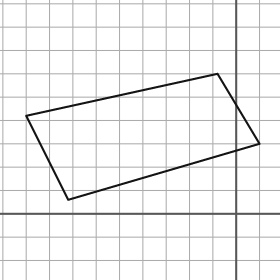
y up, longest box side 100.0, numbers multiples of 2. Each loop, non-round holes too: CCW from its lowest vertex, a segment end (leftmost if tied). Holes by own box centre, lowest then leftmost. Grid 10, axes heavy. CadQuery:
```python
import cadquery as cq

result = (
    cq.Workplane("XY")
    .moveTo(-72.0, 6.0)
    .lineTo(10.0, 30.0)
    .lineTo(-8.0, 60.0)
    .lineTo(-90.0, 42.0)
    .close()
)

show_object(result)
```